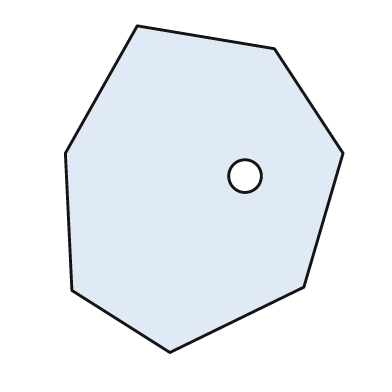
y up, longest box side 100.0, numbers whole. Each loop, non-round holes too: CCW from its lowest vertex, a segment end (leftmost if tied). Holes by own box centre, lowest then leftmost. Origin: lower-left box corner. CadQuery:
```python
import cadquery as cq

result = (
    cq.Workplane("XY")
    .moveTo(32.0, 0.0)
    .lineTo(73.0, 20.0)
    .lineTo(85.0, 61.0)
    .lineTo(64.0, 93.0)
    .lineTo(22.0, 100.0)
    .lineTo(0.0, 61.0)
    .lineTo(2.0, 19.0)
    .close()
    .moveTo(55.0, 54.0)
    .circle(5.0)
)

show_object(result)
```